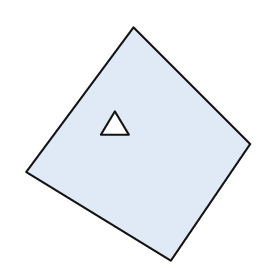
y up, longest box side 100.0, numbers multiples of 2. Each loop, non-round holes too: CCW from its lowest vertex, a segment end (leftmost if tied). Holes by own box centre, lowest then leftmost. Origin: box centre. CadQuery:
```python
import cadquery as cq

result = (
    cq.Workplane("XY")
    .moveTo(14.0, -50.0)
    .lineTo(48.0, 0.0)
    .lineTo(-2.0, 50.0)
    .lineTo(-48.0, -12.0)
    .close()
    .moveTo(-16.0, 4.0)
    .lineTo(-4.0, 4.0)
    .lineTo(-10.0, 14.0)
    .close()
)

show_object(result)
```